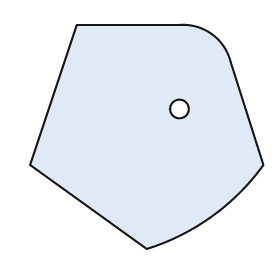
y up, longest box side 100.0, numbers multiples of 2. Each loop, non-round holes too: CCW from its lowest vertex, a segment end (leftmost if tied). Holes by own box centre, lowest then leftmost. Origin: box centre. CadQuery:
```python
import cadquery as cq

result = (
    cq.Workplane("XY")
    .moveTo(0.0, -48.0)
    .threePointArc((28.0, -34.0), (50.0, -12.0))
    .lineTo(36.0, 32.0)
    .threePointArc((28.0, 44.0), (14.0, 48.0))
    .lineTo(-30.0, 48.0)
    .lineTo(-50.0, -12.0)
    .close()
    .moveTo(14.0, 12.0)
    .circle(4.0)
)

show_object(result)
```